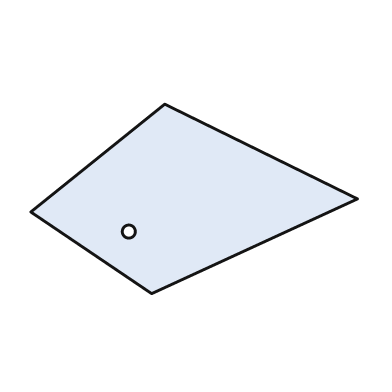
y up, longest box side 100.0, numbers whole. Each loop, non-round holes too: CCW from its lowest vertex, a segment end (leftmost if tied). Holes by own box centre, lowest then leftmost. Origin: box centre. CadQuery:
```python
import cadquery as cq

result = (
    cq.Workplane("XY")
    .moveTo(-13.0, -29.0)
    .lineTo(50.0, 0.0)
    .lineTo(-9.0, 29.0)
    .lineTo(-50.0, -4.0)
    .close()
    .moveTo(-20.0, -10.0)
    .circle(2.0)
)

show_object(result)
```